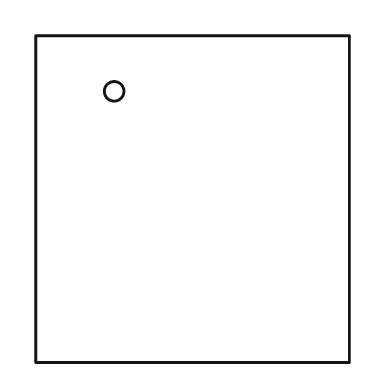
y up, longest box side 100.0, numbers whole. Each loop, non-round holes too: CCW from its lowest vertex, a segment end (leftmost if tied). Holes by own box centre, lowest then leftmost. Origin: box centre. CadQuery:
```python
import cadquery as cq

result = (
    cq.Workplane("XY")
    .moveTo(-48.0, -50.0)
    .lineTo(48.0, -50.0)
    .lineTo(48.0, 50.0)
    .lineTo(-48.0, 50.0)
    .close()
    .moveTo(-24.0, 33.0)
    .circle(3.0)
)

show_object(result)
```